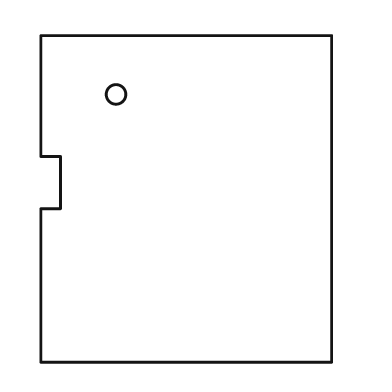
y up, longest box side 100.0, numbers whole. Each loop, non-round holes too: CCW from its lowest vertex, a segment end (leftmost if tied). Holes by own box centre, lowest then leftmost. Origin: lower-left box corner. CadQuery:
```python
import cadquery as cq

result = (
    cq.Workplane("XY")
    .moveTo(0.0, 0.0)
    .lineTo(89.0, 0.0)
    .lineTo(89.0, 100.0)
    .lineTo(0.0, 100.0)
    .lineTo(0.0, 63.0)
    .lineTo(6.0, 63.0)
    .lineTo(6.0, 47.0)
    .lineTo(0.0, 47.0)
    .close()
    .moveTo(23.0, 82.0)
    .circle(3.0)
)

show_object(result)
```